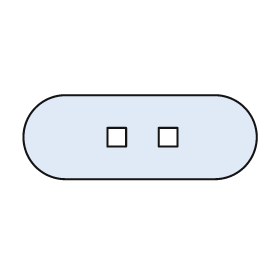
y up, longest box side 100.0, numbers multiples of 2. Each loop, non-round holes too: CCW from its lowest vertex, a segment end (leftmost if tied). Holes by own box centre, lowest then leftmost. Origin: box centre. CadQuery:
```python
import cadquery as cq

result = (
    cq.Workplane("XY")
    .moveTo(-32.0, -18.0)
    .lineTo(32.0, -18.0)
    .threePointArc((50.0, 0.0), (32.0, 18.0))
    .lineTo(-32.0, 18.0)
    .threePointArc((-50.0, 0.0), (-32.0, -18.0))
    .close()
    .moveTo(-14.0, -4.0)
    .lineTo(-6.0, -4.0)
    .lineTo(-6.0, 4.0)
    .lineTo(-14.0, 4.0)
    .close()
    .moveTo(8.0, -4.0)
    .lineTo(16.0, -4.0)
    .lineTo(16.0, 4.0)
    .lineTo(8.0, 4.0)
    .close()
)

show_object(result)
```